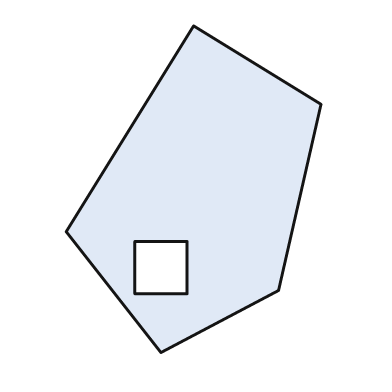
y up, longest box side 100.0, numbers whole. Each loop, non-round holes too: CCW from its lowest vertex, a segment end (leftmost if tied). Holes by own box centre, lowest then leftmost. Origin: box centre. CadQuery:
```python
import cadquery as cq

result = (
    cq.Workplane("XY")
    .moveTo(-10.0, -50.0)
    .lineTo(26.0, -31.0)
    .lineTo(39.0, 26.0)
    .lineTo(0.0, 50.0)
    .lineTo(-39.0, -13.0)
    .close()
    .moveTo(-18.0, -32.0)
    .lineTo(-2.0, -32.0)
    .lineTo(-2.0, -16.0)
    .lineTo(-18.0, -16.0)
    .close()
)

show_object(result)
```